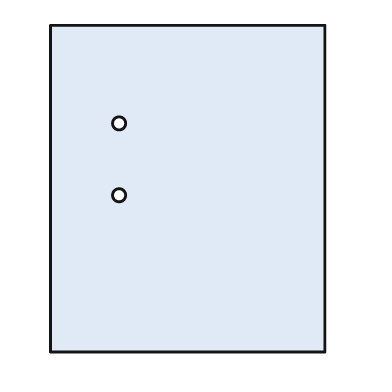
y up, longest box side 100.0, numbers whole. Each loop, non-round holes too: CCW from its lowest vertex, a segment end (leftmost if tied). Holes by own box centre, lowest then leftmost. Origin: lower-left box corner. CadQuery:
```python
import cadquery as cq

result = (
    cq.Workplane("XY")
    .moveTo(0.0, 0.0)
    .lineTo(84.0, 0.0)
    .lineTo(84.0, 100.0)
    .lineTo(0.0, 100.0)
    .close()
    .moveTo(21.0, 48.0)
    .circle(2.0)
    .moveTo(21.0, 70.0)
    .circle(2.0)
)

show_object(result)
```